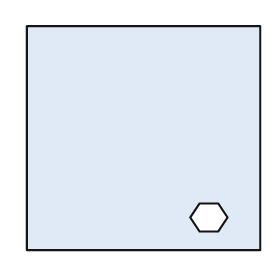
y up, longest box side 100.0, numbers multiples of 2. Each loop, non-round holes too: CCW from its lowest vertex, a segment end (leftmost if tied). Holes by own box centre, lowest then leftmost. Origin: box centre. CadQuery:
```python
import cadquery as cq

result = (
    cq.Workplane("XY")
    .moveTo(-50.0, -48.0)
    .lineTo(50.0, -48.0)
    .lineTo(50.0, 48.0)
    .lineTo(-50.0, 48.0)
    .close()
    .moveTo(24.0, -40.0)
    .lineTo(32.0, -40.0)
    .lineTo(36.0, -34.0)
    .lineTo(32.0, -28.0)
    .lineTo(24.0, -28.0)
    .lineTo(20.0, -34.0)
    .close()
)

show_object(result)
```